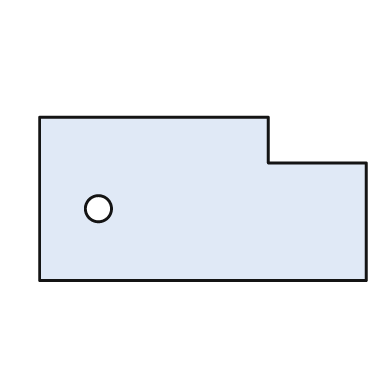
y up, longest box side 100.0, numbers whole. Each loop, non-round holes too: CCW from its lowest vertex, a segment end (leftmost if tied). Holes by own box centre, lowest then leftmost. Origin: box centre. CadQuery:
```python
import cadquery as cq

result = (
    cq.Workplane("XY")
    .moveTo(-50.0, -25.0)
    .lineTo(50.0, -25.0)
    .lineTo(50.0, 11.0)
    .lineTo(20.0, 11.0)
    .lineTo(20.0, 25.0)
    .lineTo(-50.0, 25.0)
    .close()
    .moveTo(-32.0, -3.0)
    .circle(4.0)
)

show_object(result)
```